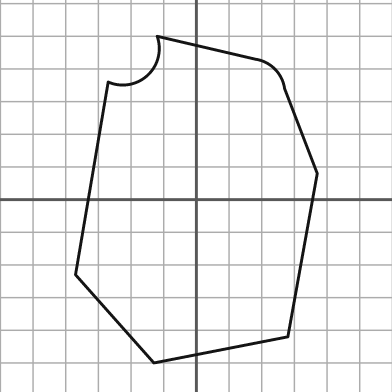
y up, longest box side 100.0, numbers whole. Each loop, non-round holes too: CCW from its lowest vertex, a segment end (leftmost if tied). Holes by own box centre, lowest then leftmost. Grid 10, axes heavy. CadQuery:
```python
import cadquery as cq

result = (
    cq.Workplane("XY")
    .moveTo(-13.0, -50.0)
    .lineTo(28.0, -42.0)
    .lineTo(37.0, 8.0)
    .lineTo(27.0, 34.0)
    .threePointArc((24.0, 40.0), (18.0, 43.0))
    .lineTo(-12.0, 50.0)
    .threePointArc((-15.0, 38.0), (-27.0, 36.0))
    .lineTo(-37.0, -23.0)
    .close()
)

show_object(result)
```